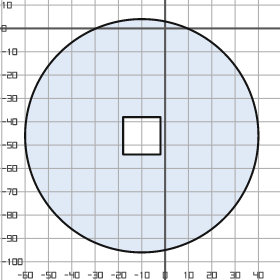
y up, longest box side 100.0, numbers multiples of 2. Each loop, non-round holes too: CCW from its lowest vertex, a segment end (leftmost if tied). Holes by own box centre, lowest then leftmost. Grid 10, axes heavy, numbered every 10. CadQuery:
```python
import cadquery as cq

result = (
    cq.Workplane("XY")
    .moveTo(-10.0, -46.0)
    .circle(50.0)
    .moveTo(-18.0, -54.0)
    .lineTo(-2.0, -54.0)
    .lineTo(-2.0, -38.0)
    .lineTo(-18.0, -38.0)
    .close()
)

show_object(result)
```